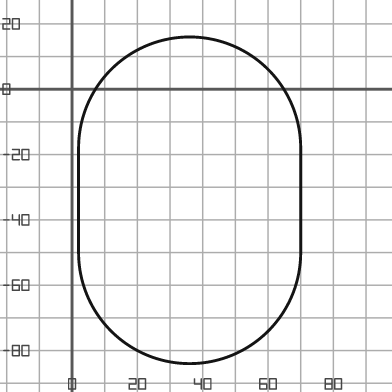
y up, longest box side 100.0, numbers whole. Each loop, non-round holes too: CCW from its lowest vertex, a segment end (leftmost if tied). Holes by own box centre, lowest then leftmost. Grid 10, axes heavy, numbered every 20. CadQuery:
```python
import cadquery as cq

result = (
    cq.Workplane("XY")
    .moveTo(2.0, -50.0)
    .threePointArc((36.0, -84.0), (70.0, -50.0))
    .lineTo(70.0, -18.0)
    .threePointArc((36.0, 16.0), (2.0, -18.0))
    .close()
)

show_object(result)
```